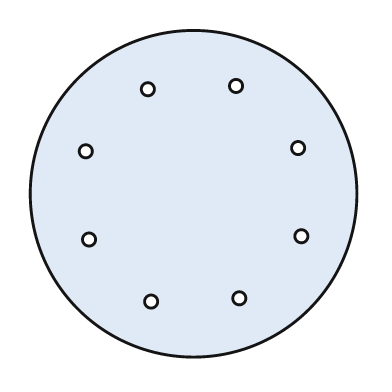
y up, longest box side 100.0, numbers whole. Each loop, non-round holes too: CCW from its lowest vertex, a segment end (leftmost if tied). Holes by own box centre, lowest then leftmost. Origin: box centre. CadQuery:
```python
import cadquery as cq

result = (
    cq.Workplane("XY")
    .moveTo(0.0, 0.0)
    .circle(50.0)
    .moveTo(-13.0, -33.0)
    .circle(2.0)
    .moveTo(14.0, -32.0)
    .circle(2.0)
    .moveTo(-32.0, -14.0)
    .circle(2.0)
    .moveTo(33.0, -13.0)
    .circle(2.0)
    .moveTo(-33.0, 13.0)
    .circle(2.0)
    .moveTo(32.0, 14.0)
    .circle(2.0)
    .moveTo(-14.0, 32.0)
    .circle(2.0)
    .moveTo(13.0, 33.0)
    .circle(2.0)
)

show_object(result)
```